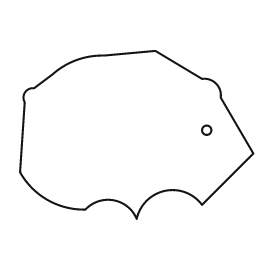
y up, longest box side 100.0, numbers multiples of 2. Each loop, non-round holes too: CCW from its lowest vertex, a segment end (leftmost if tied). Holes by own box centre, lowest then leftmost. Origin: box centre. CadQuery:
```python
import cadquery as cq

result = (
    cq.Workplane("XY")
    .moveTo(0.0, -36.0)
    .threePointArc((12.0, -24.0), (28.0, -30.0))
    .lineTo(50.0, -8.0)
    .lineTo(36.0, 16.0)
    .threePointArc((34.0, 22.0), (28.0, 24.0))
    .lineTo(8.0, 36.0)
    .lineTo(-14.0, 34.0)
    .threePointArc((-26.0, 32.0), (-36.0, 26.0))
    .lineTo(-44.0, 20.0)
    .threePointArc((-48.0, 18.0), (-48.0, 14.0))
    .lineTo(-50.0, -16.0)
    .threePointArc((-38.0, -28.0), (-22.0, -32.0))
    .threePointArc((-10.0, -28.0), (0.0, -36.0))
    .close()
    .moveTo(30.0, 2.0)
    .circle(2.0)
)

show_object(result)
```